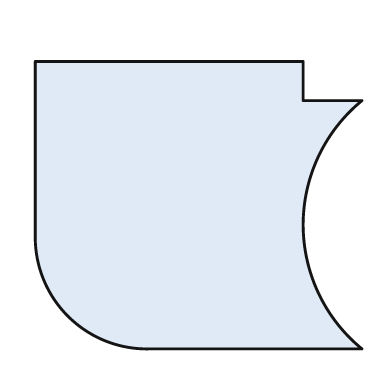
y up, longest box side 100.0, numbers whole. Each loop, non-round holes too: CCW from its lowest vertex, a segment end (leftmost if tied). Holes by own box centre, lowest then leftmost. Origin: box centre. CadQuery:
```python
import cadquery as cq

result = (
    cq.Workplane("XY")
    .moveTo(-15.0, -44.0)
    .lineTo(50.0, -44.0)
    .threePointArc((32.0, -6.0), (50.0, 32.0))
    .lineTo(32.0, 32.0)
    .lineTo(32.0, 44.0)
    .lineTo(-50.0, 44.0)
    .lineTo(-50.0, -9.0)
    .threePointArc((-40.0, -34.0), (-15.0, -44.0))
    .close()
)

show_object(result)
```